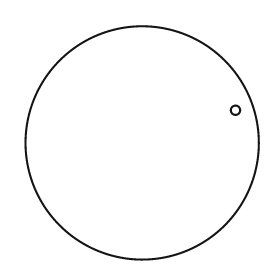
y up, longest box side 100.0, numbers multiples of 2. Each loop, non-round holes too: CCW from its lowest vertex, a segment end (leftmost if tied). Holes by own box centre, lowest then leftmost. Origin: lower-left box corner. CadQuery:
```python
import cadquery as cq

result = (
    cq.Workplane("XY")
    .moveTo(50.0, 50.0)
    .circle(50.0)
    .moveTo(90.0, 64.0)
    .circle(2.0)
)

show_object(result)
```